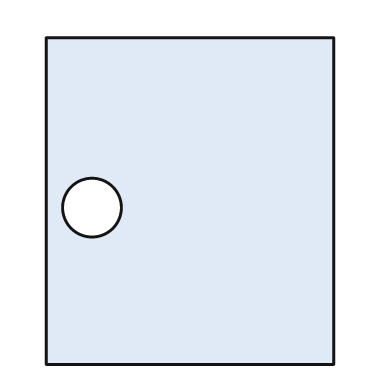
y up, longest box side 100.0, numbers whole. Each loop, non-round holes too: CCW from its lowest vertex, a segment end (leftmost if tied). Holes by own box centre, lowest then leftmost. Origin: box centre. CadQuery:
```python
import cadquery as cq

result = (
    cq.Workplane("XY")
    .moveTo(-44.0, -50.0)
    .lineTo(44.0, -50.0)
    .lineTo(44.0, 50.0)
    .lineTo(-44.0, 50.0)
    .close()
    .moveTo(-30.0, -2.0)
    .circle(9.0)
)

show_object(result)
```